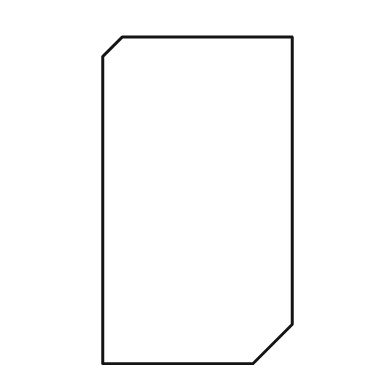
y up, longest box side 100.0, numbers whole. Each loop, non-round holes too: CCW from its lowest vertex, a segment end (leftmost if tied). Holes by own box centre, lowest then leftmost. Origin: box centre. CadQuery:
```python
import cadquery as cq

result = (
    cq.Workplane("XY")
    .moveTo(-29.0, -50.0)
    .lineTo(17.0, -50.0)
    .lineTo(29.0, -38.0)
    .lineTo(29.0, 50.0)
    .lineTo(-23.0, 50.0)
    .lineTo(-29.0, 44.0)
    .close()
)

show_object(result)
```